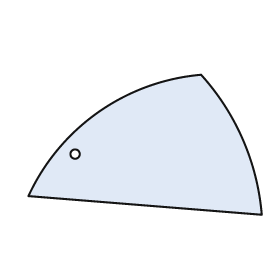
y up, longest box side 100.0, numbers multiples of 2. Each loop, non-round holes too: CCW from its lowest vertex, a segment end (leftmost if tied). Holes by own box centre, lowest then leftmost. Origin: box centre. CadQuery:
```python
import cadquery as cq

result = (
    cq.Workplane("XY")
    .moveTo(50.0, -30.0)
    .threePointArc((42.0, 2.0), (24.0, 30.0))
    .threePointArc((-20.0, 14.0), (-50.0, -22.0))
    .close()
    .moveTo(-30.0, -4.0)
    .circle(2.0)
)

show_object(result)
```